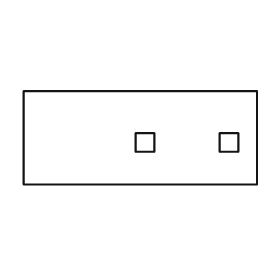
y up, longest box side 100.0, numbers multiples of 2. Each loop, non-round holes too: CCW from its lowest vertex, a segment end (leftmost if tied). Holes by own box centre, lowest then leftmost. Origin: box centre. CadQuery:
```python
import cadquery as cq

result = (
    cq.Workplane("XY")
    .moveTo(-50.0, -20.0)
    .lineTo(50.0, -20.0)
    .lineTo(50.0, 20.0)
    .lineTo(-50.0, 20.0)
    .close()
    .moveTo(-2.0, -6.0)
    .lineTo(6.0, -6.0)
    .lineTo(6.0, 2.0)
    .lineTo(-2.0, 2.0)
    .close()
    .moveTo(34.0, -6.0)
    .lineTo(42.0, -6.0)
    .lineTo(42.0, 2.0)
    .lineTo(34.0, 2.0)
    .close()
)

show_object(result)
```